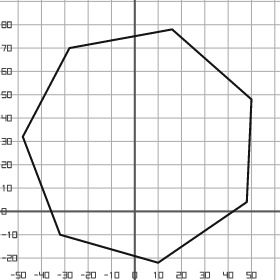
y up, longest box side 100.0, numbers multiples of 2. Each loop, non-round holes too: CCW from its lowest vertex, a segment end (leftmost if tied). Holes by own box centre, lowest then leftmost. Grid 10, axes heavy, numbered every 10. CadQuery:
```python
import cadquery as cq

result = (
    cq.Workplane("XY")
    .moveTo(10.0, -22.0)
    .lineTo(48.0, 4.0)
    .lineTo(50.0, 48.0)
    .lineTo(16.0, 78.0)
    .lineTo(-28.0, 70.0)
    .lineTo(-48.0, 32.0)
    .lineTo(-32.0, -10.0)
    .close()
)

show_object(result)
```